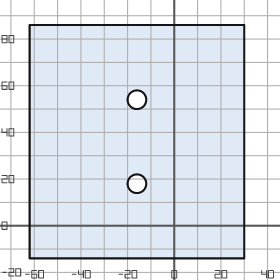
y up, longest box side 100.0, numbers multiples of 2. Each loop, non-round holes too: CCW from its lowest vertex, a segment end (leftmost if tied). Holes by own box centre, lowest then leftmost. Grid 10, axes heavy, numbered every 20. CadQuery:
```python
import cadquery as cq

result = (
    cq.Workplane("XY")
    .moveTo(-62.0, -14.0)
    .lineTo(30.0, -14.0)
    .lineTo(30.0, 86.0)
    .lineTo(-62.0, 86.0)
    .close()
    .moveTo(-16.0, 18.0)
    .circle(4.0)
    .moveTo(-16.0, 54.0)
    .circle(4.0)
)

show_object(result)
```